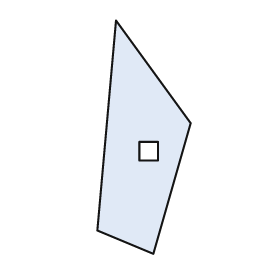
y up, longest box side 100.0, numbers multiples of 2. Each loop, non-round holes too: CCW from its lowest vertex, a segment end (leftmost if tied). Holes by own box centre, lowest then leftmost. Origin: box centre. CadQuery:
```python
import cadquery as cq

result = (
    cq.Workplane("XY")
    .moveTo(4.0, -50.0)
    .lineTo(20.0, 6.0)
    .lineTo(-12.0, 50.0)
    .lineTo(-20.0, -40.0)
    .close()
    .moveTo(-2.0, -10.0)
    .lineTo(6.0, -10.0)
    .lineTo(6.0, -2.0)
    .lineTo(-2.0, -2.0)
    .close()
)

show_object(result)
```